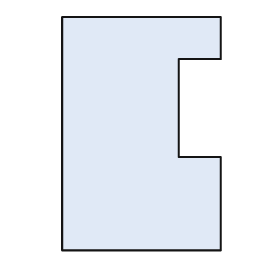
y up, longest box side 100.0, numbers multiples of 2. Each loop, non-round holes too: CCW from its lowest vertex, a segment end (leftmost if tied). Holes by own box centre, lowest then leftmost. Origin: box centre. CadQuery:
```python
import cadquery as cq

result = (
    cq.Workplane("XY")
    .moveTo(-34.0, -50.0)
    .lineTo(34.0, -50.0)
    .lineTo(34.0, -10.0)
    .lineTo(16.0, -10.0)
    .lineTo(16.0, 32.0)
    .lineTo(34.0, 32.0)
    .lineTo(34.0, 50.0)
    .lineTo(-34.0, 50.0)
    .close()
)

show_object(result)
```